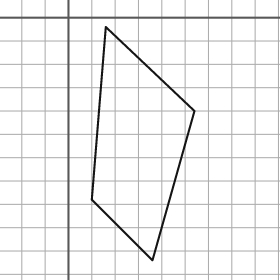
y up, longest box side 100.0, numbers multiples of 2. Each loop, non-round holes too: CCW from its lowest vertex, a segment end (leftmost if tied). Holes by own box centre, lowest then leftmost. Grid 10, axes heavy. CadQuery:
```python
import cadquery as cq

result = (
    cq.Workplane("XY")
    .moveTo(36.0, -104.0)
    .lineTo(54.0, -40.0)
    .lineTo(16.0, -4.0)
    .lineTo(10.0, -78.0)
    .close()
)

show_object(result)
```